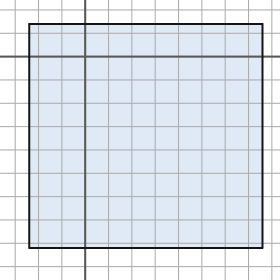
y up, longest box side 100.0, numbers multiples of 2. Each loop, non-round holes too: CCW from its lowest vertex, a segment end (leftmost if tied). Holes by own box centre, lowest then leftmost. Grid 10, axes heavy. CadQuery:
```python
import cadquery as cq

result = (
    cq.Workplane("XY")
    .moveTo(-24.0, -82.0)
    .lineTo(76.0, -82.0)
    .lineTo(76.0, 14.0)
    .lineTo(-24.0, 14.0)
    .close()
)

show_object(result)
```